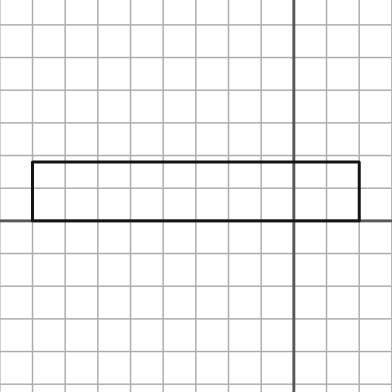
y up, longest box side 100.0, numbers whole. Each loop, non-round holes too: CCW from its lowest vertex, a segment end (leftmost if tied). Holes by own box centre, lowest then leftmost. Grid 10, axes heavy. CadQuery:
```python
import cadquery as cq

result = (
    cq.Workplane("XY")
    .moveTo(-80.0, 0.0)
    .lineTo(20.0, 0.0)
    .lineTo(20.0, 18.0)
    .lineTo(-80.0, 18.0)
    .close()
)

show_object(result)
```